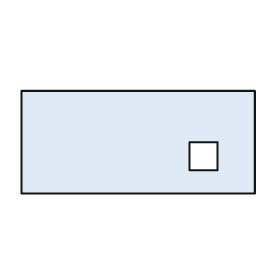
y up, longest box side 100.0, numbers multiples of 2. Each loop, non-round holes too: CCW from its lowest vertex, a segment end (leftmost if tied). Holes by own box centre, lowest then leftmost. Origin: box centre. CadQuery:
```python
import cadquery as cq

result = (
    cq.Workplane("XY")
    .moveTo(-50.0, -22.0)
    .lineTo(50.0, -22.0)
    .lineTo(50.0, 22.0)
    .lineTo(-50.0, 22.0)
    .close()
    .moveTo(22.0, -12.0)
    .lineTo(34.0, -12.0)
    .lineTo(34.0, 0.0)
    .lineTo(22.0, 0.0)
    .close()
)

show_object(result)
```